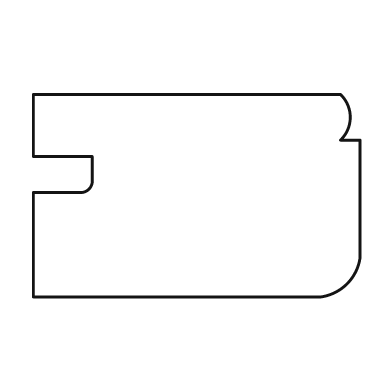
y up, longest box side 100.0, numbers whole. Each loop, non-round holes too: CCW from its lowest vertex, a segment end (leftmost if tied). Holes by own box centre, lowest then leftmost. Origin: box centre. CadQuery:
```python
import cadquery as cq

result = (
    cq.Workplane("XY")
    .moveTo(-50.0, -31.0)
    .lineTo(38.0, -31.0)
    .threePointArc((46.0, -27.0), (50.0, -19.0))
    .lineTo(50.0, 17.0)
    .lineTo(44.0, 17.0)
    .threePointArc((47.0, 24.0), (44.0, 31.0))
    .lineTo(-50.0, 31.0)
    .lineTo(-50.0, 12.0)
    .lineTo(-32.0, 12.0)
    .lineTo(-32.0, 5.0)
    .threePointArc((-33.0, 2.0), (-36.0, 1.0))
    .lineTo(-50.0, 1.0)
    .close()
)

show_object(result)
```